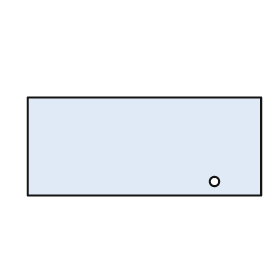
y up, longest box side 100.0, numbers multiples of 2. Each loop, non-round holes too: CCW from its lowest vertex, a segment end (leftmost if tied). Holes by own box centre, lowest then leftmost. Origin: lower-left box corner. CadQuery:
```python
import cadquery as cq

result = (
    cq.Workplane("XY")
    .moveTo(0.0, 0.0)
    .lineTo(100.0, 0.0)
    .lineTo(100.0, 42.0)
    .lineTo(0.0, 42.0)
    .close()
    .moveTo(80.0, 6.0)
    .circle(2.0)
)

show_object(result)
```